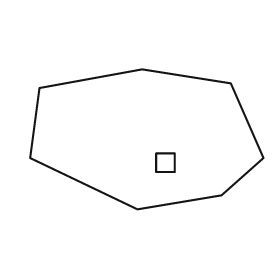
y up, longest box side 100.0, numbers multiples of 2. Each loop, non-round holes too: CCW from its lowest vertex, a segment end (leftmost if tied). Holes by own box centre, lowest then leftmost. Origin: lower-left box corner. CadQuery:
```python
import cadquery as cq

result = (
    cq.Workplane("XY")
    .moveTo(46.0, 0.0)
    .lineTo(82.0, 6.0)
    .lineTo(100.0, 22.0)
    .lineTo(86.0, 54.0)
    .lineTo(48.0, 60.0)
    .lineTo(4.0, 52.0)
    .lineTo(0.0, 22.0)
    .close()
    .moveTo(54.0, 16.0)
    .lineTo(62.0, 16.0)
    .lineTo(62.0, 24.0)
    .lineTo(54.0, 24.0)
    .close()
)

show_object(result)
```